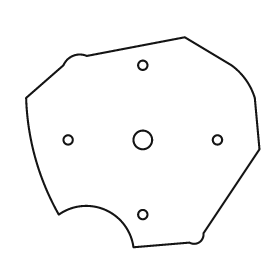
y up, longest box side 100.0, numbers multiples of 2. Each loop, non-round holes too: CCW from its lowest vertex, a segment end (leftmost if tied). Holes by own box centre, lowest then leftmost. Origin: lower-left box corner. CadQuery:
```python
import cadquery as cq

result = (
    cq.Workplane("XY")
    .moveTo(46.0, 0.0)
    .lineTo(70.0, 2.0)
    .threePointArc((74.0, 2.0), (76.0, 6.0))
    .lineTo(100.0, 42.0)
    .lineTo(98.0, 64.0)
    .threePointArc((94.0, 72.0), (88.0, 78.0))
    .lineTo(68.0, 90.0)
    .lineTo(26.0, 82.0)
    .threePointArc((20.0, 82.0), (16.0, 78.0))
    .lineTo(0.0, 64.0)
    .threePointArc((4.0, 38.0), (14.0, 14.0))
    .threePointArc((34.0, 16.0), (46.0, 0.0))
    .close()
    .moveTo(50.0, 14.0)
    .circle(2.0)
    .moveTo(18.0, 46.0)
    .circle(2.0)
    .moveTo(50.0, 46.0)
    .circle(4.0)
    .moveTo(82.0, 46.0)
    .circle(2.0)
    .moveTo(50.0, 78.0)
    .circle(2.0)
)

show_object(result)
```